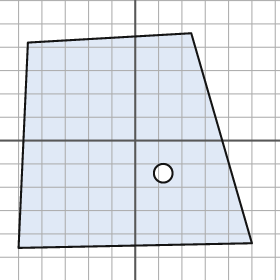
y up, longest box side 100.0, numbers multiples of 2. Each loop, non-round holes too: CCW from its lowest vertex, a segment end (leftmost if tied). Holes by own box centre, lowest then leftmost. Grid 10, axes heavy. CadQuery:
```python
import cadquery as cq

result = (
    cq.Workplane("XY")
    .moveTo(-50.0, -46.0)
    .lineTo(50.0, -44.0)
    .lineTo(24.0, 46.0)
    .lineTo(-46.0, 42.0)
    .close()
    .moveTo(12.0, -14.0)
    .circle(4.0)
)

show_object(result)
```